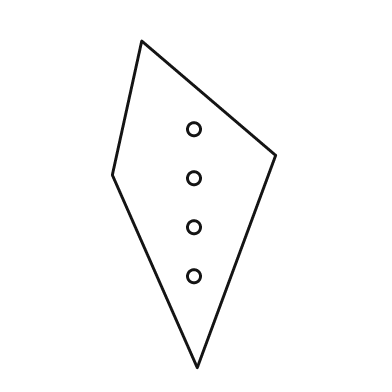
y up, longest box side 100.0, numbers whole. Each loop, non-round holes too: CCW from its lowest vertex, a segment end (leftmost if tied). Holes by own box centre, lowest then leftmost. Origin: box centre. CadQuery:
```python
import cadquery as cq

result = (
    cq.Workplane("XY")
    .moveTo(1.0, -50.0)
    .lineTo(25.0, 15.0)
    .lineTo(-16.0, 50.0)
    .lineTo(-25.0, 9.0)
    .close()
    .moveTo(0.0, -22.0)
    .circle(2.0)
    .moveTo(0.0, -7.0)
    .circle(2.0)
    .moveTo(0.0, 8.0)
    .circle(2.0)
    .moveTo(0.0, 23.0)
    .circle(2.0)
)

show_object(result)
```